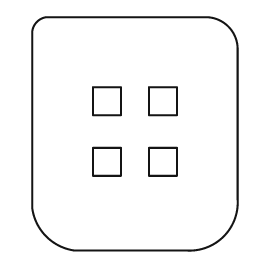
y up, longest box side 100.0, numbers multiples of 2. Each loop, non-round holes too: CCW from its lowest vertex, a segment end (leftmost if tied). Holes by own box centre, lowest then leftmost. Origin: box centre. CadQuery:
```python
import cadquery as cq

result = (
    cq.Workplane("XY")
    .moveTo(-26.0, -50.0)
    .lineTo(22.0, -50.0)
    .threePointArc((38.0, -44.0), (44.0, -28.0))
    .lineTo(44.0, 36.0)
    .threePointArc((40.0, 46.0), (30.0, 50.0))
    .lineTo(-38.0, 50.0)
    .threePointArc((-42.0, 48.0), (-44.0, 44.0))
    .lineTo(-44.0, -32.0)
    .threePointArc((-38.0, -44.0), (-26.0, -50.0))
    .close()
    .moveTo(-18.0, -18.0)
    .lineTo(-6.0, -18.0)
    .lineTo(-6.0, -6.0)
    .lineTo(-18.0, -6.0)
    .close()
    .moveTo(6.0, -18.0)
    .lineTo(18.0, -18.0)
    .lineTo(18.0, -6.0)
    .lineTo(6.0, -6.0)
    .close()
    .moveTo(-18.0, 8.0)
    .lineTo(-6.0, 8.0)
    .lineTo(-6.0, 20.0)
    .lineTo(-18.0, 20.0)
    .close()
    .moveTo(6.0, 8.0)
    .lineTo(18.0, 8.0)
    .lineTo(18.0, 20.0)
    .lineTo(6.0, 20.0)
    .close()
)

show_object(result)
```